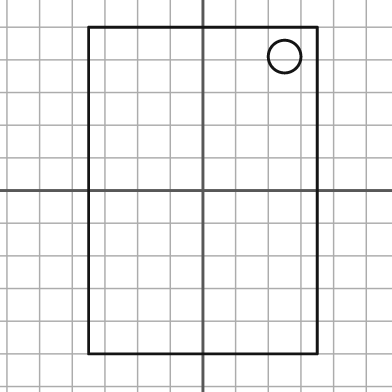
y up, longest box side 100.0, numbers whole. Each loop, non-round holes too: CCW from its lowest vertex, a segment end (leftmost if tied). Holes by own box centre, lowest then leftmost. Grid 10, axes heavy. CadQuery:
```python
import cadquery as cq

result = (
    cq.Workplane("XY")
    .moveTo(-35.0, -50.0)
    .lineTo(35.0, -50.0)
    .lineTo(35.0, 50.0)
    .lineTo(-35.0, 50.0)
    .close()
    .moveTo(25.0, 41.0)
    .circle(5.0)
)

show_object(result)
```